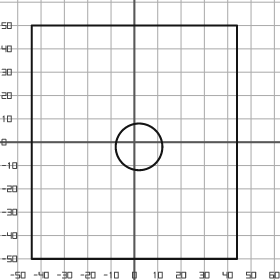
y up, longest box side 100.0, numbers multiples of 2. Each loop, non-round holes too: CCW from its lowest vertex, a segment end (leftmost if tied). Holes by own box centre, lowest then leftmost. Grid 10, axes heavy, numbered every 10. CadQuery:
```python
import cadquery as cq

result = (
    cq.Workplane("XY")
    .moveTo(-44.0, -50.0)
    .lineTo(44.0, -50.0)
    .lineTo(44.0, 50.0)
    .lineTo(-44.0, 50.0)
    .close()
    .moveTo(2.0, -2.0)
    .circle(10.0)
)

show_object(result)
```